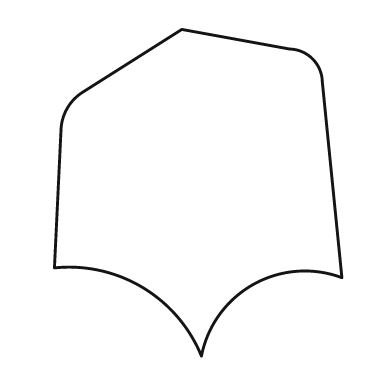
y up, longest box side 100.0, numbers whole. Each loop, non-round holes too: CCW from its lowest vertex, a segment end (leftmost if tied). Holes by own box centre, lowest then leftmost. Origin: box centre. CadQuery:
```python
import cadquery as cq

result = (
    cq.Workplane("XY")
    .moveTo(1.0, -50.0)
    .threePointArc((17.0, -28.0), (44.0, -26.0))
    .lineTo(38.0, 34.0)
    .threePointArc((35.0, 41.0), (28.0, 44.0))
    .lineTo(-5.0, 50.0)
    .lineTo(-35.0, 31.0)
    .threePointArc((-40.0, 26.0), (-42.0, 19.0))
    .lineTo(-44.0, -23.0)
    .threePointArc((-17.0, -29.0), (1.0, -50.0))
    .close()
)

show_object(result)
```